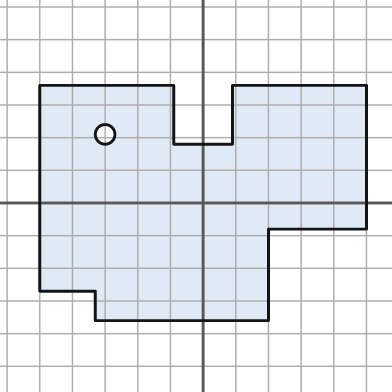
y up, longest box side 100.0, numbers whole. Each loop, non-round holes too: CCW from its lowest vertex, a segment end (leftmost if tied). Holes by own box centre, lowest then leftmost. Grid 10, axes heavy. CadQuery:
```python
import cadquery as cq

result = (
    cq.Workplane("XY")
    .moveTo(-33.0, -36.0)
    .lineTo(20.0, -36.0)
    .lineTo(20.0, -8.0)
    .lineTo(50.0, -8.0)
    .lineTo(50.0, 36.0)
    .lineTo(9.0, 36.0)
    .lineTo(9.0, 18.0)
    .lineTo(-9.0, 18.0)
    .lineTo(-9.0, 36.0)
    .lineTo(-50.0, 36.0)
    .lineTo(-50.0, -27.0)
    .lineTo(-33.0, -27.0)
    .close()
    .moveTo(-30.0, 21.0)
    .circle(3.0)
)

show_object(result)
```